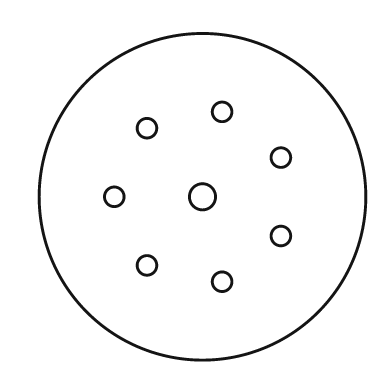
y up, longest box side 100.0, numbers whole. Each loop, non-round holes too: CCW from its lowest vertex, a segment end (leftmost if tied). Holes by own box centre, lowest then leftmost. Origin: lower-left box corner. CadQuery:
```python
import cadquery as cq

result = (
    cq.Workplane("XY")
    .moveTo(50.0, 50.0)
    .circle(50.0)
    .moveTo(56.0, 24.0)
    .circle(3.0)
    .moveTo(33.0, 29.0)
    .circle(3.0)
    .moveTo(74.0, 38.0)
    .circle(3.0)
    .moveTo(23.0, 50.0)
    .circle(3.0)
    .moveTo(50.0, 50.0)
    .circle(4.0)
    .moveTo(74.0, 62.0)
    .circle(3.0)
    .moveTo(33.0, 71.0)
    .circle(3.0)
    .moveTo(56.0, 76.0)
    .circle(3.0)
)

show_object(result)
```